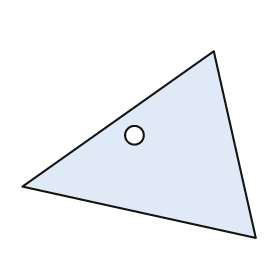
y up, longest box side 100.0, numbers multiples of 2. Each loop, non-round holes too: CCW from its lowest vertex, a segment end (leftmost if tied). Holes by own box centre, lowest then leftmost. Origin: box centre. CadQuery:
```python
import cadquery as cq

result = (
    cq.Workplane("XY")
    .moveTo(50.0, -40.0)
    .lineTo(32.0, 40.0)
    .lineTo(-50.0, -18.0)
    .close()
    .moveTo(-2.0, 4.0)
    .circle(4.0)
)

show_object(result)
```